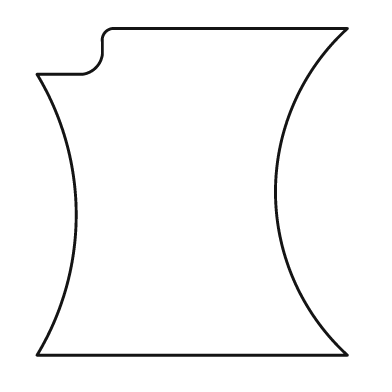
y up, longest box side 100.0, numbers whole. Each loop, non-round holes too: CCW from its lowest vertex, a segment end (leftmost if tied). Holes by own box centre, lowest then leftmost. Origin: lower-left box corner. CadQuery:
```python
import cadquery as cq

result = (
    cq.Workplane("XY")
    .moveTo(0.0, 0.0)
    .lineTo(95.0, 0.0)
    .threePointArc((73.0, 50.0), (95.0, 100.0))
    .lineTo(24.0, 100.0)
    .threePointArc((21.0, 99.0), (20.0, 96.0))
    .lineTo(20.0, 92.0)
    .threePointArc((18.0, 88.0), (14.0, 86.0))
    .lineTo(0.0, 86.0)
    .threePointArc((12.0, 43.0), (0.0, 0.0))
    .close()
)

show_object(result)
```